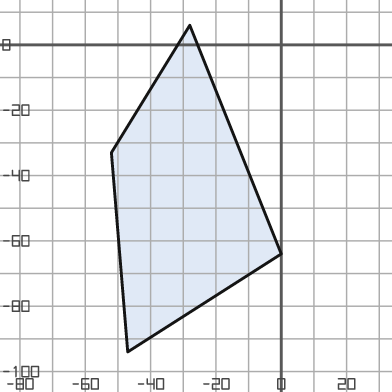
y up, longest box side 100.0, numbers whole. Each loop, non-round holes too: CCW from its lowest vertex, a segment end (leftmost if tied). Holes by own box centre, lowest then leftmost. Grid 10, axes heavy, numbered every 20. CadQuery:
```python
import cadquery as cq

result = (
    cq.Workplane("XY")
    .moveTo(-47.0, -94.0)
    .lineTo(0.0, -64.0)
    .lineTo(-28.0, 6.0)
    .lineTo(-52.0, -33.0)
    .close()
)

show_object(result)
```